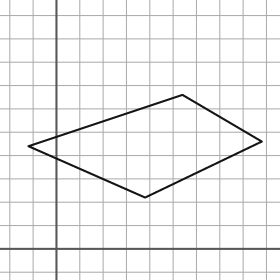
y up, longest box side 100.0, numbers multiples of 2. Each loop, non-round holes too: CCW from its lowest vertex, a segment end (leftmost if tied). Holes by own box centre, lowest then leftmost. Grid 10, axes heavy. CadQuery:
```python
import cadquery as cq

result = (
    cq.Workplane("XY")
    .moveTo(38.0, 22.0)
    .lineTo(88.0, 46.0)
    .lineTo(54.0, 66.0)
    .lineTo(-12.0, 44.0)
    .close()
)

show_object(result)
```